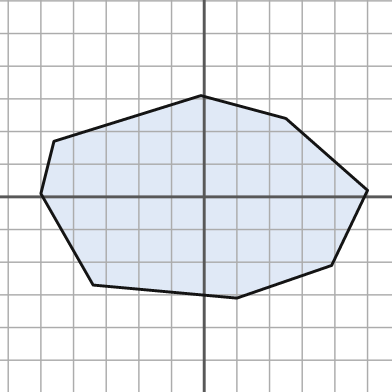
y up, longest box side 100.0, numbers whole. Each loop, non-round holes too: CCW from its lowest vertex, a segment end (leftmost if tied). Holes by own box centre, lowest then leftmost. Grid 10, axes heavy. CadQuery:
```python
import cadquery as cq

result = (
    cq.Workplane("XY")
    .moveTo(10.0, -31.0)
    .lineTo(39.0, -21.0)
    .lineTo(50.0, 2.0)
    .lineTo(25.0, 24.0)
    .lineTo(-1.0, 31.0)
    .lineTo(-46.0, 17.0)
    .lineTo(-50.0, 1.0)
    .lineTo(-34.0, -27.0)
    .close()
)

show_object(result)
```